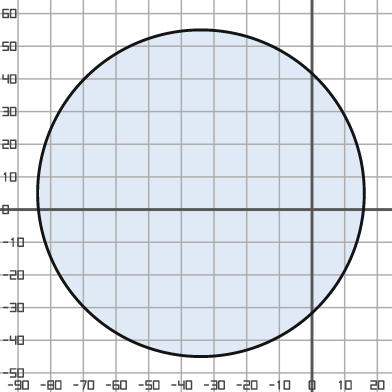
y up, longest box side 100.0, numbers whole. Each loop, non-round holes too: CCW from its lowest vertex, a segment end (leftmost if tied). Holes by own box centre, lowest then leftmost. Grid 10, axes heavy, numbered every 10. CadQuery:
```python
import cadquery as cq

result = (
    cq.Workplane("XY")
    .moveTo(-34.0, 5.0)
    .circle(50.0)
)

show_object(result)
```